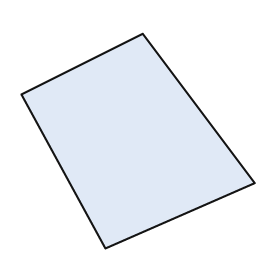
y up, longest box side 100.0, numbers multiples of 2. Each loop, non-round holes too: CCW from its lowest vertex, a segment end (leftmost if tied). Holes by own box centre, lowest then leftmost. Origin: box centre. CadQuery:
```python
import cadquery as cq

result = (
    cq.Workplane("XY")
    .moveTo(-14.0, -46.0)
    .lineTo(50.0, -18.0)
    .lineTo(2.0, 46.0)
    .lineTo(-50.0, 20.0)
    .close()
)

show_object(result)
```